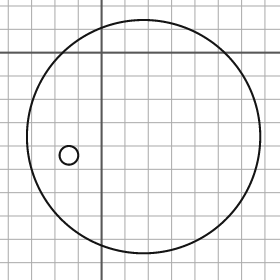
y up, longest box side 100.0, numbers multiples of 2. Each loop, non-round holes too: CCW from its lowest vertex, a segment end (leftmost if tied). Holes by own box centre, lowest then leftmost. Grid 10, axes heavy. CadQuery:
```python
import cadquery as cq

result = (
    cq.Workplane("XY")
    .moveTo(18.0, -36.0)
    .circle(50.0)
    .moveTo(-14.0, -44.0)
    .circle(4.0)
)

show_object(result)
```